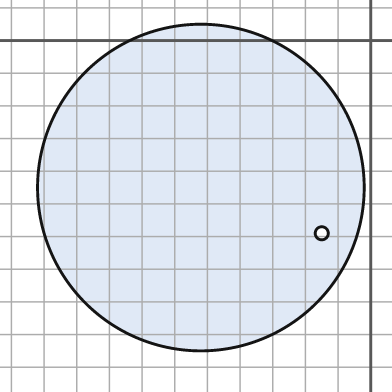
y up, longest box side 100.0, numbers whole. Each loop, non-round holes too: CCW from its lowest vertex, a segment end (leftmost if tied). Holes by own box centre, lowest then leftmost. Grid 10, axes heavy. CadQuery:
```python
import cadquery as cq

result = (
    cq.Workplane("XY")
    .moveTo(-52.0, -45.0)
    .circle(50.0)
    .moveTo(-15.0, -59.0)
    .circle(2.0)
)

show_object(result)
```